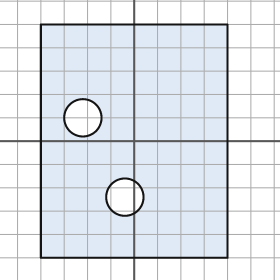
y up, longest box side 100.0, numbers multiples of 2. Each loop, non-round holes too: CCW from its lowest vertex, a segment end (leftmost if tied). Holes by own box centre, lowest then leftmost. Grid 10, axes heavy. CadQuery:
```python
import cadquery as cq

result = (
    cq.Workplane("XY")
    .moveTo(-40.0, -50.0)
    .lineTo(40.0, -50.0)
    .lineTo(40.0, 50.0)
    .lineTo(-40.0, 50.0)
    .close()
    .moveTo(-4.0, -24.0)
    .circle(8.0)
    .moveTo(-22.0, 10.0)
    .circle(8.0)
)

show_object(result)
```